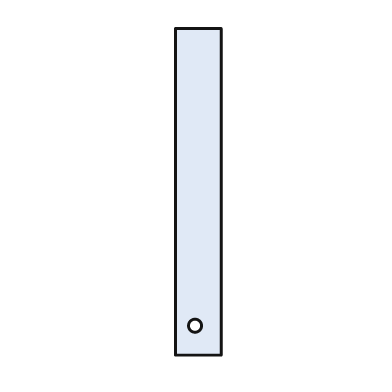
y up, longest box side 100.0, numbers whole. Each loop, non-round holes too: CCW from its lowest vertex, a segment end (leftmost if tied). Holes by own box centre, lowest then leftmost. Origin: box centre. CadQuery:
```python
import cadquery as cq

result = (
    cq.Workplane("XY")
    .moveTo(-7.0, -50.0)
    .lineTo(7.0, -50.0)
    .lineTo(7.0, 50.0)
    .lineTo(-7.0, 50.0)
    .close()
    .moveTo(-1.0, -41.0)
    .circle(2.0)
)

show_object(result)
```